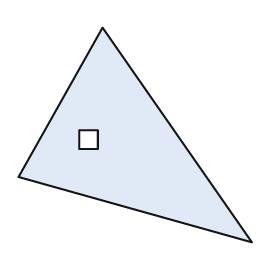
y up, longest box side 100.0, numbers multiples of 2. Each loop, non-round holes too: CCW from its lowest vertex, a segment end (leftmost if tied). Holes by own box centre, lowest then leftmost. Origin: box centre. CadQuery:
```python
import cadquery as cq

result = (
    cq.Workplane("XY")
    .moveTo(50.0, -46.0)
    .lineTo(-14.0, 46.0)
    .lineTo(-50.0, -18.0)
    .close()
    .moveTo(-24.0, -6.0)
    .lineTo(-16.0, -6.0)
    .lineTo(-16.0, 2.0)
    .lineTo(-24.0, 2.0)
    .close()
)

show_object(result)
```